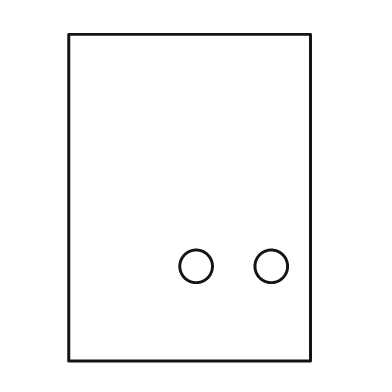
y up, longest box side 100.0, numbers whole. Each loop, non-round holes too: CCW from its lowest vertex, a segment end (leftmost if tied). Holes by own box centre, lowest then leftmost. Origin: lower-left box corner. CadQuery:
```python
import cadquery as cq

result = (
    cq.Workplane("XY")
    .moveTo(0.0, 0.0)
    .lineTo(74.0, 0.0)
    .lineTo(74.0, 100.0)
    .lineTo(0.0, 100.0)
    .close()
    .moveTo(39.0, 29.0)
    .circle(5.0)
    .moveTo(62.0, 29.0)
    .circle(5.0)
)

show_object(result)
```